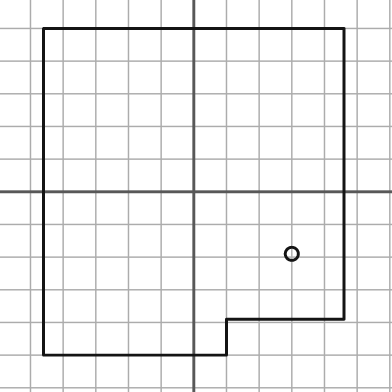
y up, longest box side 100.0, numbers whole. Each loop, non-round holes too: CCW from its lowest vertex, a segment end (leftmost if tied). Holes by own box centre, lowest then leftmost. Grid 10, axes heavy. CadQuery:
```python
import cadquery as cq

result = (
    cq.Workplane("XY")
    .moveTo(-46.0, -50.0)
    .lineTo(10.0, -50.0)
    .lineTo(10.0, -39.0)
    .lineTo(46.0, -39.0)
    .lineTo(46.0, 50.0)
    .lineTo(-46.0, 50.0)
    .close()
    .moveTo(30.0, -19.0)
    .circle(2.0)
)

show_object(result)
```